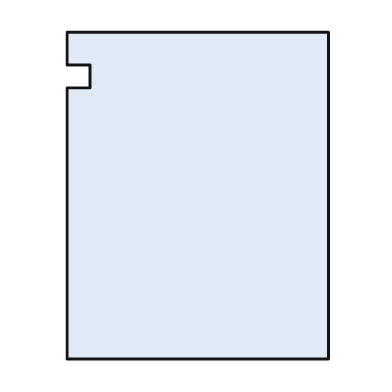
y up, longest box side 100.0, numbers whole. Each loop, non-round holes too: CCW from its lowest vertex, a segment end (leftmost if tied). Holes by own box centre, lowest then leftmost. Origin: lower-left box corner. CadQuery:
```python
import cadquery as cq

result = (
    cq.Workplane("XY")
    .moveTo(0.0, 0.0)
    .lineTo(80.0, 0.0)
    .lineTo(80.0, 100.0)
    .lineTo(0.0, 100.0)
    .lineTo(0.0, 90.0)
    .lineTo(7.0, 90.0)
    .lineTo(7.0, 83.0)
    .lineTo(0.0, 83.0)
    .close()
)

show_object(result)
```